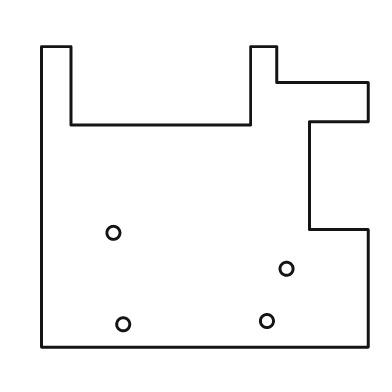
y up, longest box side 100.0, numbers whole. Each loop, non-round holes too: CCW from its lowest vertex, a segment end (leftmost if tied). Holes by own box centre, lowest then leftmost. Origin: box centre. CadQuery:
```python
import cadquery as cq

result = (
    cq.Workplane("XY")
    .moveTo(-50.0, -46.0)
    .lineTo(50.0, -46.0)
    .lineTo(50.0, -10.0)
    .lineTo(32.0, -10.0)
    .lineTo(32.0, 23.0)
    .lineTo(50.0, 23.0)
    .lineTo(50.0, 35.0)
    .lineTo(22.0, 35.0)
    .lineTo(22.0, 46.0)
    .lineTo(14.0, 46.0)
    .lineTo(14.0, 22.0)
    .lineTo(-41.0, 22.0)
    .lineTo(-41.0, 46.0)
    .lineTo(-50.0, 46.0)
    .close()
    .moveTo(-25.0, -39.0)
    .circle(2.0)
    .moveTo(19.0, -38.0)
    .circle(2.0)
    .moveTo(25.0, -22.0)
    .circle(2.0)
    .moveTo(-28.0, -11.0)
    .circle(2.0)
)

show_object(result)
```